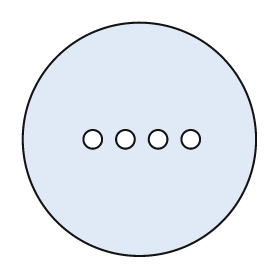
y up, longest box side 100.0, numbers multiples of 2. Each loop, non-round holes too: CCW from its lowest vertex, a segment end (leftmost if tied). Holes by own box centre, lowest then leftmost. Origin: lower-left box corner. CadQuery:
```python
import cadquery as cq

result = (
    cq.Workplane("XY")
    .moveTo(50.0, 50.0)
    .circle(50.0)
    .moveTo(30.0, 50.0)
    .circle(4.0)
    .moveTo(44.0, 50.0)
    .circle(4.0)
    .moveTo(58.0, 50.0)
    .circle(4.0)
    .moveTo(72.0, 50.0)
    .circle(4.0)
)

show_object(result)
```